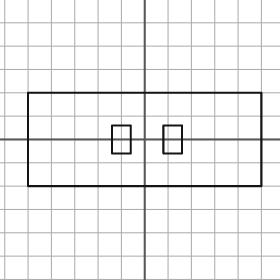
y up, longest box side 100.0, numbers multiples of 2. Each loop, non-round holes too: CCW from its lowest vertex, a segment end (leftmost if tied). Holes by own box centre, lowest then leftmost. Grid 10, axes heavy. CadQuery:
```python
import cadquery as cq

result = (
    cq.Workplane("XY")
    .moveTo(-50.0, -20.0)
    .lineTo(50.0, -20.0)
    .lineTo(50.0, 20.0)
    .lineTo(-50.0, 20.0)
    .close()
    .moveTo(-14.0, -6.0)
    .lineTo(-6.0, -6.0)
    .lineTo(-6.0, 6.0)
    .lineTo(-14.0, 6.0)
    .close()
    .moveTo(8.0, -6.0)
    .lineTo(16.0, -6.0)
    .lineTo(16.0, 6.0)
    .lineTo(8.0, 6.0)
    .close()
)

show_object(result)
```